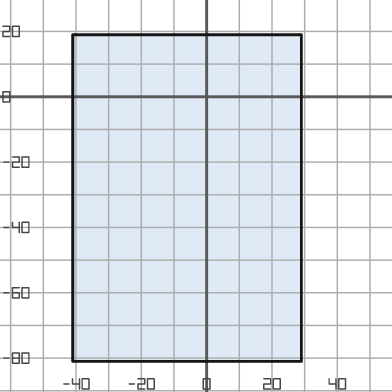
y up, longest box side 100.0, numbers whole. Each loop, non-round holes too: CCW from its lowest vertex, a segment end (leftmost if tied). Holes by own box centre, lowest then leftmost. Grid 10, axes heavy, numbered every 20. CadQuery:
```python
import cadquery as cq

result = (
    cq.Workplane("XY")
    .moveTo(-41.0, -81.0)
    .lineTo(29.0, -81.0)
    .lineTo(29.0, 19.0)
    .lineTo(-41.0, 19.0)
    .close()
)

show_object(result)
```